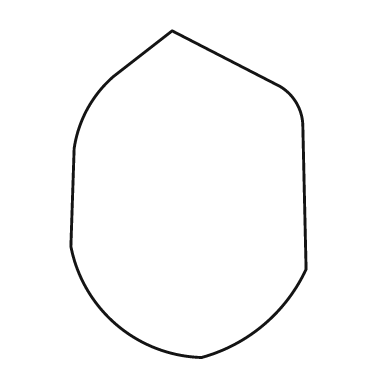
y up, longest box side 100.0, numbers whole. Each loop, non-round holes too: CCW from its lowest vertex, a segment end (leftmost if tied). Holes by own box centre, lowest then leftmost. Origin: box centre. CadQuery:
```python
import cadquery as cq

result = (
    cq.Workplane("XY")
    .moveTo(4.0, -50.0)
    .threePointArc((23.0, -40.0), (36.0, -23.0))
    .lineTo(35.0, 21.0)
    .threePointArc((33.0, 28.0), (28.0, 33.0))
    .lineTo(-5.0, 50.0)
    .lineTo(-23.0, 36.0)
    .threePointArc((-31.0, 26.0), (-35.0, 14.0))
    .lineTo(-36.0, -16.0)
    .threePointArc((-22.0, -40.0), (4.0, -50.0))
    .close()
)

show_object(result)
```